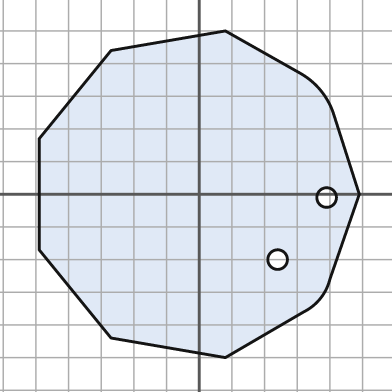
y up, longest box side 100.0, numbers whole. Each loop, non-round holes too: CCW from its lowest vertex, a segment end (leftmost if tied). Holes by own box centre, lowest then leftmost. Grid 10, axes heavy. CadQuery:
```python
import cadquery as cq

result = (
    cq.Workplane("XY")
    .moveTo(8.0, -50.0)
    .lineTo(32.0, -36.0)
    .threePointArc((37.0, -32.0), (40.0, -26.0))
    .lineTo(49.0, 0.0)
    .lineTo(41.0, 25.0)
    .threePointArc((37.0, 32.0), (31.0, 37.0))
    .lineTo(8.0, 50.0)
    .lineTo(-27.0, 44.0)
    .lineTo(-49.0, 17.0)
    .lineTo(-49.0, -17.0)
    .lineTo(-27.0, -44.0)
    .close()
    .moveTo(24.0, -20.0)
    .circle(3.0)
    .moveTo(39.0, -1.0)
    .circle(3.0)
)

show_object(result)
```